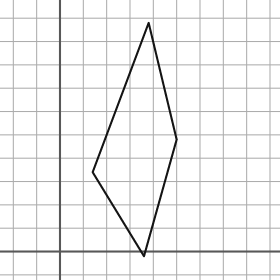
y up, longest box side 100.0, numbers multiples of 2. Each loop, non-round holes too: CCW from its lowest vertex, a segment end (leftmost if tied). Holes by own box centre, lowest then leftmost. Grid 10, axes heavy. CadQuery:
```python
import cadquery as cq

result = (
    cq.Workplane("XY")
    .moveTo(36.0, -2.0)
    .lineTo(50.0, 48.0)
    .lineTo(38.0, 98.0)
    .lineTo(14.0, 34.0)
    .close()
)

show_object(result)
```